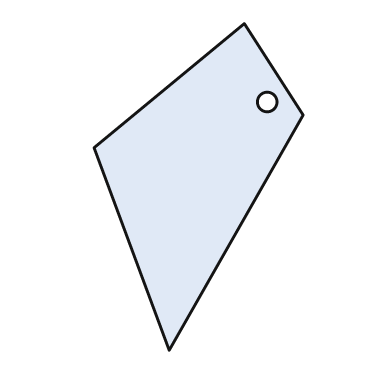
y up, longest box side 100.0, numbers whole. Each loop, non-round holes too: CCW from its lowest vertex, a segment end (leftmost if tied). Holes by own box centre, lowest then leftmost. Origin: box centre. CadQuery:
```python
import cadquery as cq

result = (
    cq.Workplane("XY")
    .moveTo(-9.0, -50.0)
    .lineTo(32.0, 22.0)
    .lineTo(14.0, 50.0)
    .lineTo(-32.0, 12.0)
    .close()
    .moveTo(21.0, 26.0)
    .circle(3.0)
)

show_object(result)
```